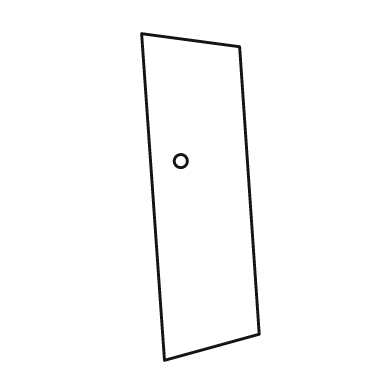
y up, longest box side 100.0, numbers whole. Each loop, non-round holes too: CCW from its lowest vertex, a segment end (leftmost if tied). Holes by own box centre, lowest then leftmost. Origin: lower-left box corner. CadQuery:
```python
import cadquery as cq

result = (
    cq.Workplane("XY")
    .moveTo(7.0, 0.0)
    .lineTo(36.0, 8.0)
    .lineTo(30.0, 96.0)
    .lineTo(0.0, 100.0)
    .close()
    .moveTo(12.0, 61.0)
    .circle(2.0)
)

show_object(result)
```